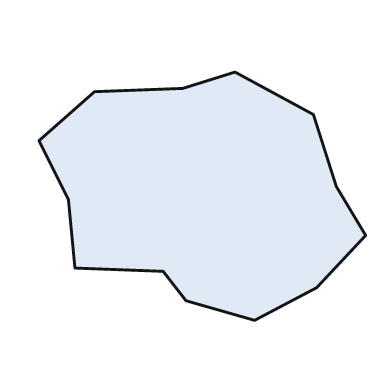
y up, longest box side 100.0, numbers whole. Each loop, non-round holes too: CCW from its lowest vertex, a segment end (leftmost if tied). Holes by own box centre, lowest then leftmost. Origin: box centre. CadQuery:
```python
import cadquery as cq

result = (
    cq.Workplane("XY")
    .moveTo(16.0, -38.0)
    .lineTo(35.0, -28.0)
    .lineTo(50.0, -12.0)
    .lineTo(41.0, 3.0)
    .lineTo(34.0, 25.0)
    .lineTo(10.0, 38.0)
    .lineTo(-6.0, 33.0)
    .lineTo(-33.0, 32.0)
    .lineTo(-50.0, 17.0)
    .lineTo(-41.0, -1.0)
    .lineTo(-39.0, -22.0)
    .lineTo(-12.0, -23.0)
    .lineTo(-5.0, -32.0)
    .close()
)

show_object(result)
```